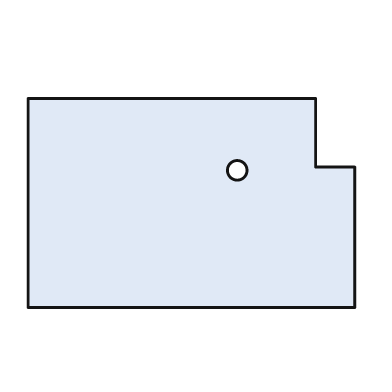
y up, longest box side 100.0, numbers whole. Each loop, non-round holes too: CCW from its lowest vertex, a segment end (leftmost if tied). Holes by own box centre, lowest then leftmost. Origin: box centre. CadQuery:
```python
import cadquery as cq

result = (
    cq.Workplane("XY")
    .moveTo(-50.0, -32.0)
    .lineTo(50.0, -32.0)
    .lineTo(50.0, 11.0)
    .lineTo(38.0, 11.0)
    .lineTo(38.0, 32.0)
    .lineTo(-50.0, 32.0)
    .close()
    .moveTo(14.0, 10.0)
    .circle(3.0)
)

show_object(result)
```